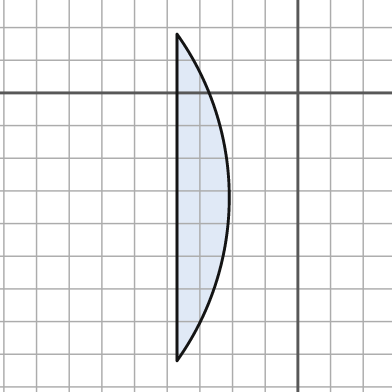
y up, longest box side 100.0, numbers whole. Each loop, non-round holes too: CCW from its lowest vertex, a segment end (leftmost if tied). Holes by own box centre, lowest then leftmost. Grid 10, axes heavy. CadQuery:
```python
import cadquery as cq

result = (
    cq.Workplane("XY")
    .moveTo(-37.0, -82.0)
    .threePointArc((-21.0, -32.0), (-37.0, 18.0))
    .close()
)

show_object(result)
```